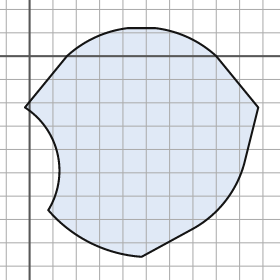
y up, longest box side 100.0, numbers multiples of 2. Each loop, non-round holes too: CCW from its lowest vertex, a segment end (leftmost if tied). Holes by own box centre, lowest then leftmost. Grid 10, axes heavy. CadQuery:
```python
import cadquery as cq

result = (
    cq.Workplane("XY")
    .moveTo(48.0, -86.0)
    .lineTo(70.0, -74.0)
    .threePointArc((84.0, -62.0), (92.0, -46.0))
    .lineTo(98.0, -22.0)
    .lineTo(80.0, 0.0)
    .threePointArc((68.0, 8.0), (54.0, 12.0))
    .lineTo(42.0, 12.0)
    .threePointArc((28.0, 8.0), (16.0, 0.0))
    .lineTo(-2.0, -22.0)
    .threePointArc((12.0, -42.0), (8.0, -66.0))
    .threePointArc((26.0, -80.0), (48.0, -86.0))
    .close()
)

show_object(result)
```